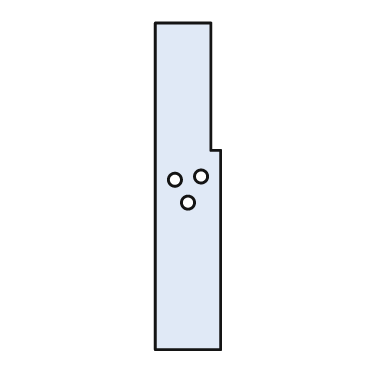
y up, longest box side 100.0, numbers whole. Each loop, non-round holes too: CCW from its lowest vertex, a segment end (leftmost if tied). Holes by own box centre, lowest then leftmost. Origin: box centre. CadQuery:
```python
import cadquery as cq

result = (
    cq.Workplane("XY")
    .moveTo(-10.0, -50.0)
    .lineTo(10.0, -50.0)
    .lineTo(10.0, 11.0)
    .lineTo(7.0, 11.0)
    .lineTo(7.0, 50.0)
    .lineTo(-10.0, 50.0)
    .close()
    .moveTo(0.0, -5.0)
    .circle(2.0)
    .moveTo(-4.0, 2.0)
    .circle(2.0)
    .moveTo(4.0, 3.0)
    .circle(2.0)
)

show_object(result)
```